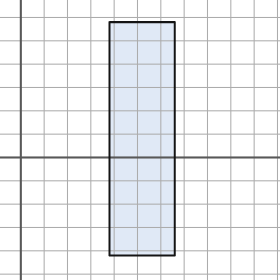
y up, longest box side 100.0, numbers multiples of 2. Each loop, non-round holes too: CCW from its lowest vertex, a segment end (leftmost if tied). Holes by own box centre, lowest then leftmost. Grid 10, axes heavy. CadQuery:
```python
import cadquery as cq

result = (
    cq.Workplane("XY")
    .moveTo(38.0, -42.0)
    .lineTo(66.0, -42.0)
    .lineTo(66.0, 58.0)
    .lineTo(38.0, 58.0)
    .close()
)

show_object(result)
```